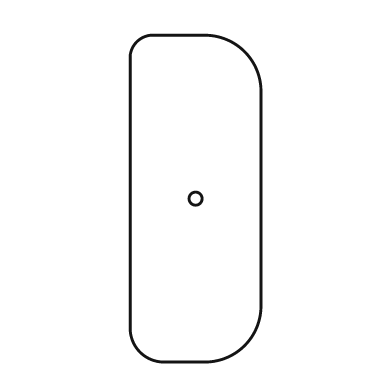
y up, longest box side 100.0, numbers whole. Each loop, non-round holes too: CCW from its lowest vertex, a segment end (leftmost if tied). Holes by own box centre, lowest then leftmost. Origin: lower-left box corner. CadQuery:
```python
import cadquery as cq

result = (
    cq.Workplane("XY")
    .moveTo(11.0, 0.0)
    .lineTo(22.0, 0.0)
    .threePointArc((35.0, 5.0), (40.0, 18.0))
    .lineTo(40.0, 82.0)
    .threePointArc((35.0, 95.0), (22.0, 100.0))
    .lineTo(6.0, 100.0)
    .threePointArc((2.0, 98.0), (0.0, 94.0))
    .lineTo(0.0, 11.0)
    .threePointArc((3.0, 3.0), (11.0, 0.0))
    .close()
    .moveTo(20.0, 50.0)
    .circle(2.0)
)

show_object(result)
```